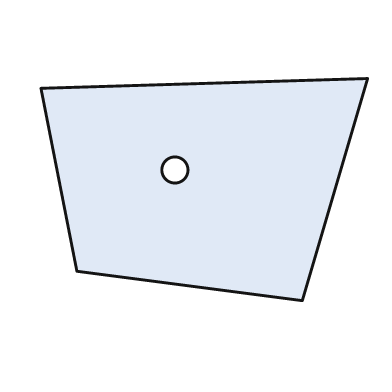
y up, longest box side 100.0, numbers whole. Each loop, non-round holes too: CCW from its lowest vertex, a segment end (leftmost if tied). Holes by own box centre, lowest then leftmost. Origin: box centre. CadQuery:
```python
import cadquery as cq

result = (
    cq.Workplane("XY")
    .moveTo(30.0, -34.0)
    .lineTo(50.0, 34.0)
    .lineTo(-50.0, 31.0)
    .lineTo(-39.0, -25.0)
    .close()
    .moveTo(-9.0, 6.0)
    .circle(4.0)
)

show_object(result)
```